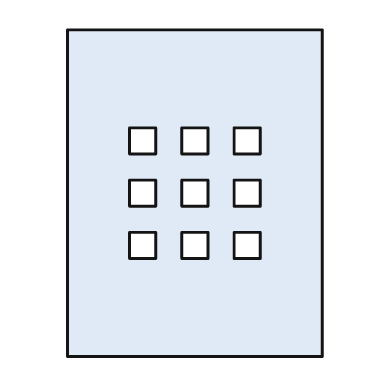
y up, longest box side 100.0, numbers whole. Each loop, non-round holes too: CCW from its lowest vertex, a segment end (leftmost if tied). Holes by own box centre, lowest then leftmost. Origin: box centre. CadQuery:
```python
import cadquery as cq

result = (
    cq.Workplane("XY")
    .moveTo(-39.0, -50.0)
    .lineTo(39.0, -50.0)
    .lineTo(39.0, 50.0)
    .lineTo(-39.0, 50.0)
    .close()
    .moveTo(-20.0, -20.0)
    .lineTo(-12.0, -20.0)
    .lineTo(-12.0, -12.0)
    .lineTo(-20.0, -12.0)
    .close()
    .moveTo(-4.0, -20.0)
    .lineTo(4.0, -20.0)
    .lineTo(4.0, -12.0)
    .lineTo(-4.0, -12.0)
    .close()
    .moveTo(12.0, -20.0)
    .lineTo(20.0, -20.0)
    .lineTo(20.0, -12.0)
    .lineTo(12.0, -12.0)
    .close()
    .moveTo(-20.0, -4.0)
    .lineTo(-12.0, -4.0)
    .lineTo(-12.0, 4.0)
    .lineTo(-20.0, 4.0)
    .close()
    .moveTo(-4.0, -4.0)
    .lineTo(4.0, -4.0)
    .lineTo(4.0, 4.0)
    .lineTo(-4.0, 4.0)
    .close()
    .moveTo(12.0, -4.0)
    .lineTo(20.0, -4.0)
    .lineTo(20.0, 4.0)
    .lineTo(12.0, 4.0)
    .close()
    .moveTo(-20.0, 12.0)
    .lineTo(-12.0, 12.0)
    .lineTo(-12.0, 20.0)
    .lineTo(-20.0, 20.0)
    .close()
    .moveTo(-4.0, 12.0)
    .lineTo(4.0, 12.0)
    .lineTo(4.0, 20.0)
    .lineTo(-4.0, 20.0)
    .close()
    .moveTo(12.0, 12.0)
    .lineTo(20.0, 12.0)
    .lineTo(20.0, 20.0)
    .lineTo(12.0, 20.0)
    .close()
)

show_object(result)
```